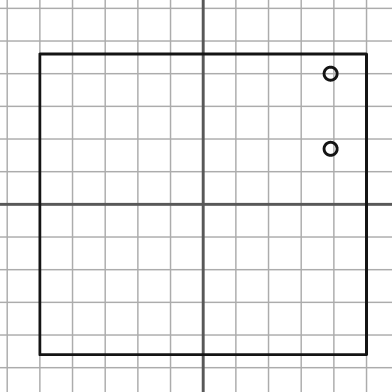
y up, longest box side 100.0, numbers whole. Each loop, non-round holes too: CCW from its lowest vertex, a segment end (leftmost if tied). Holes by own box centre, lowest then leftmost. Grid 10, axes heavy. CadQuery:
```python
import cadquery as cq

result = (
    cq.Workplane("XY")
    .moveTo(-50.0, -46.0)
    .lineTo(50.0, -46.0)
    .lineTo(50.0, 46.0)
    .lineTo(-50.0, 46.0)
    .close()
    .moveTo(39.0, 17.0)
    .circle(2.0)
    .moveTo(39.0, 40.0)
    .circle(2.0)
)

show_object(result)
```